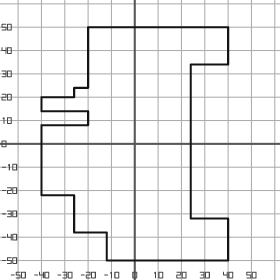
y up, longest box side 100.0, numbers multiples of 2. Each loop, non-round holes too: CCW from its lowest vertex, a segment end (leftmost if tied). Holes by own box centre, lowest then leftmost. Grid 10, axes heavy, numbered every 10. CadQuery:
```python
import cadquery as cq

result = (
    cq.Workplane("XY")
    .moveTo(-12.0, -50.0)
    .lineTo(40.0, -50.0)
    .lineTo(40.0, -32.0)
    .lineTo(24.0, -32.0)
    .lineTo(24.0, 34.0)
    .lineTo(40.0, 34.0)
    .lineTo(40.0, 50.0)
    .lineTo(-20.0, 50.0)
    .lineTo(-20.0, 24.0)
    .lineTo(-26.0, 24.0)
    .lineTo(-26.0, 20.0)
    .lineTo(-40.0, 20.0)
    .lineTo(-40.0, 14.0)
    .lineTo(-20.0, 14.0)
    .lineTo(-20.0, 8.0)
    .lineTo(-40.0, 8.0)
    .lineTo(-40.0, -22.0)
    .lineTo(-26.0, -22.0)
    .lineTo(-26.0, -38.0)
    .lineTo(-12.0, -38.0)
    .close()
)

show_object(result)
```